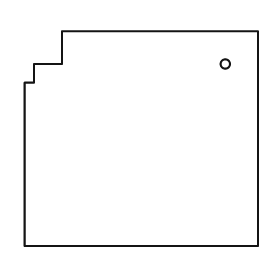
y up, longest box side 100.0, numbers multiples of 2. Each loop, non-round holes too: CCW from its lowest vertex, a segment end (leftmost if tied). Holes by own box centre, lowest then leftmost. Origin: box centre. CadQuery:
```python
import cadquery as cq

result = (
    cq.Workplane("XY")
    .moveTo(-50.0, -46.0)
    .lineTo(50.0, -46.0)
    .lineTo(50.0, 46.0)
    .lineTo(-34.0, 46.0)
    .lineTo(-34.0, 32.0)
    .lineTo(-46.0, 32.0)
    .lineTo(-46.0, 24.0)
    .lineTo(-50.0, 24.0)
    .close()
    .moveTo(36.0, 32.0)
    .circle(2.0)
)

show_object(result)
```